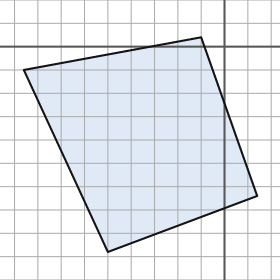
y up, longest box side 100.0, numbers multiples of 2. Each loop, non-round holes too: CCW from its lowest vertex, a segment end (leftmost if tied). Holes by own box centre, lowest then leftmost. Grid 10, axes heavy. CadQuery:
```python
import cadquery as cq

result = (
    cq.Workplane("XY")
    .moveTo(-50.0, -88.0)
    .lineTo(14.0, -64.0)
    .lineTo(-10.0, 4.0)
    .lineTo(-86.0, -10.0)
    .close()
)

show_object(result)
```